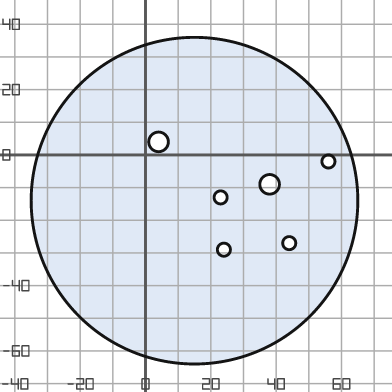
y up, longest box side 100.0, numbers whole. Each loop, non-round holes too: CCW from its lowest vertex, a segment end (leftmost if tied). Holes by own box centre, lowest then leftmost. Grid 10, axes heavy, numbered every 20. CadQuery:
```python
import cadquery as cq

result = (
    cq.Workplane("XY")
    .moveTo(15.0, -14.0)
    .circle(50.0)
    .moveTo(24.0, -29.0)
    .circle(2.0)
    .moveTo(44.0, -27.0)
    .circle(2.0)
    .moveTo(23.0, -13.0)
    .circle(2.0)
    .moveTo(38.0, -9.0)
    .circle(3.0)
    .moveTo(56.0, -2.0)
    .circle(2.0)
    .moveTo(4.0, 4.0)
    .circle(3.0)
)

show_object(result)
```